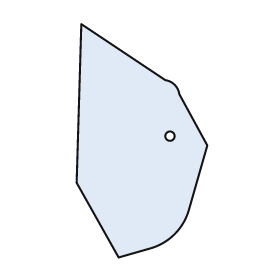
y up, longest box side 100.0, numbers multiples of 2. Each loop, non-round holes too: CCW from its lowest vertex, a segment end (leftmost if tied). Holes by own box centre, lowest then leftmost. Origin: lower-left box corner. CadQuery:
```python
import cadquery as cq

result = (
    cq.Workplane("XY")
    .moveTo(18.0, 0.0)
    .lineTo(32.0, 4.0)
    .threePointArc((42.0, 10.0), (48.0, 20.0))
    .lineTo(56.0, 48.0)
    .lineTo(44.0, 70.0)
    .threePointArc((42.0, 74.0), (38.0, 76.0))
    .lineTo(2.0, 100.0)
    .lineTo(0.0, 32.0)
    .close()
    .moveTo(40.0, 52.0)
    .circle(2.0)
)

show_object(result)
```